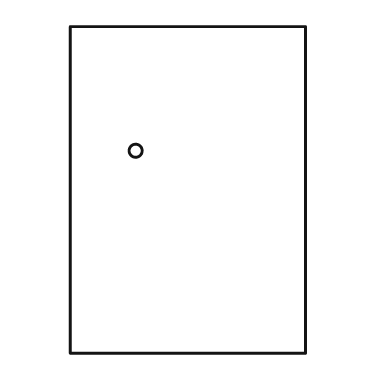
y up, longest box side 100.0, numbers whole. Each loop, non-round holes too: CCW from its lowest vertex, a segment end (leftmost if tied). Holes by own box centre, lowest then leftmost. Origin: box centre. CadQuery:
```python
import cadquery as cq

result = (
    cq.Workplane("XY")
    .moveTo(-36.0, -50.0)
    .lineTo(36.0, -50.0)
    .lineTo(36.0, 50.0)
    .lineTo(-36.0, 50.0)
    .close()
    .moveTo(-16.0, 12.0)
    .circle(2.0)
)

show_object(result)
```